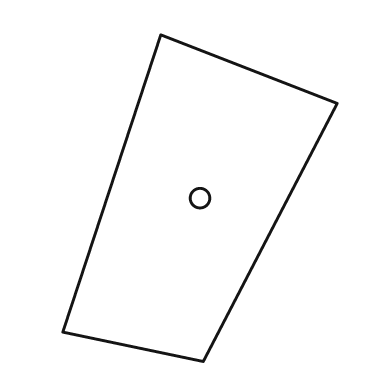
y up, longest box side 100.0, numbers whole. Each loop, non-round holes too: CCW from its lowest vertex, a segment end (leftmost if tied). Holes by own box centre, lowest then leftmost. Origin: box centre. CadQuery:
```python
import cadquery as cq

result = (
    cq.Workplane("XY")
    .moveTo(1.0, -50.0)
    .lineTo(42.0, 29.0)
    .lineTo(-12.0, 50.0)
    .lineTo(-42.0, -41.0)
    .close()
    .moveTo(0.0, 0.0)
    .circle(3.0)
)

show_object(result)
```